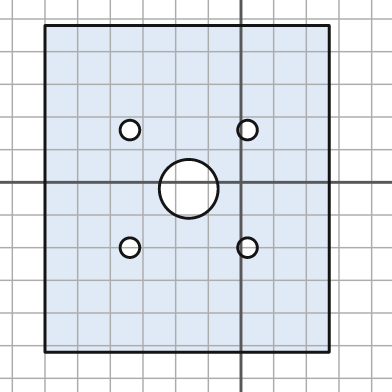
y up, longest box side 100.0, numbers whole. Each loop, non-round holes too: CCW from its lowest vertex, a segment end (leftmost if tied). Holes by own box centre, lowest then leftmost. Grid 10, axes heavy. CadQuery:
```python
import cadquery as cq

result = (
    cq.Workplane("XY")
    .moveTo(-60.0, -52.0)
    .lineTo(27.0, -52.0)
    .lineTo(27.0, 48.0)
    .lineTo(-60.0, 48.0)
    .close()
    .moveTo(-34.0, -20.0)
    .circle(3.0)
    .moveTo(2.0, -20.0)
    .circle(3.0)
    .moveTo(-16.0, -2.0)
    .circle(9.0)
    .moveTo(-34.0, 16.0)
    .circle(3.0)
    .moveTo(2.0, 16.0)
    .circle(3.0)
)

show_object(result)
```